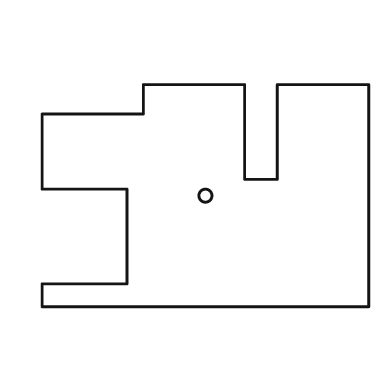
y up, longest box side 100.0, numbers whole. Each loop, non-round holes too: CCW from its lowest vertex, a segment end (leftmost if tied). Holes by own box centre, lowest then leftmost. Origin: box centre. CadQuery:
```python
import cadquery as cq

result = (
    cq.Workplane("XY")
    .moveTo(-50.0, -34.0)
    .lineTo(50.0, -34.0)
    .lineTo(50.0, 34.0)
    .lineTo(22.0, 34.0)
    .lineTo(22.0, 5.0)
    .lineTo(12.0, 5.0)
    .lineTo(12.0, 34.0)
    .lineTo(-19.0, 34.0)
    .lineTo(-19.0, 25.0)
    .lineTo(-50.0, 25.0)
    .lineTo(-50.0, 2.0)
    .lineTo(-24.0, 2.0)
    .lineTo(-24.0, -27.0)
    .lineTo(-50.0, -27.0)
    .close()
    .moveTo(0.0, 0.0)
    .circle(2.0)
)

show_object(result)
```